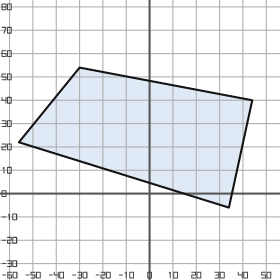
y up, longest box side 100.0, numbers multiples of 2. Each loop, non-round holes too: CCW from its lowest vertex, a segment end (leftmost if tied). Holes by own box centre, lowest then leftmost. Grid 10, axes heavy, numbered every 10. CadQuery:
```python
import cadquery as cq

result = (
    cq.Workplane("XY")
    .moveTo(34.0, -6.0)
    .lineTo(44.0, 40.0)
    .lineTo(-30.0, 54.0)
    .lineTo(-56.0, 22.0)
    .close()
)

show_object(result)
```